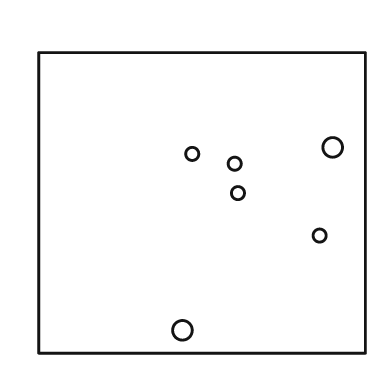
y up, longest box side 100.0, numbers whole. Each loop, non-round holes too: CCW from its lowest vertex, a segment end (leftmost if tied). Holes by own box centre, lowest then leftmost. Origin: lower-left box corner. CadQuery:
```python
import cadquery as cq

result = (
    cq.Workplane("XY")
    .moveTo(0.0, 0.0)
    .lineTo(100.0, 0.0)
    .lineTo(100.0, 92.0)
    .lineTo(0.0, 92.0)
    .close()
    .moveTo(44.0, 7.0)
    .circle(3.0)
    .moveTo(86.0, 36.0)
    .circle(2.0)
    .moveTo(61.0, 49.0)
    .circle(2.0)
    .moveTo(60.0, 58.0)
    .circle(2.0)
    .moveTo(47.0, 61.0)
    .circle(2.0)
    .moveTo(90.0, 63.0)
    .circle(3.0)
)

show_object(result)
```